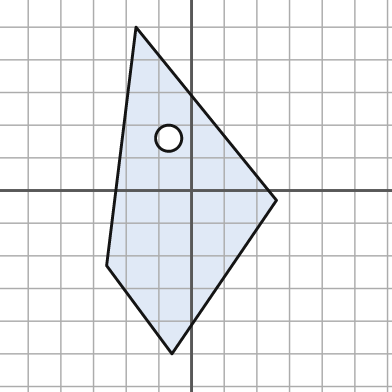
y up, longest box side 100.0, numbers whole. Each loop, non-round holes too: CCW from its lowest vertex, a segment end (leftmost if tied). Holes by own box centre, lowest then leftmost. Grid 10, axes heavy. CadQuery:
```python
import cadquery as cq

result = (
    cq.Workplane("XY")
    .moveTo(-6.0, -50.0)
    .lineTo(26.0, -3.0)
    .lineTo(-17.0, 50.0)
    .lineTo(-26.0, -23.0)
    .close()
    .moveTo(-7.0, 16.0)
    .circle(4.0)
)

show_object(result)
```